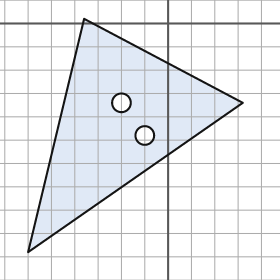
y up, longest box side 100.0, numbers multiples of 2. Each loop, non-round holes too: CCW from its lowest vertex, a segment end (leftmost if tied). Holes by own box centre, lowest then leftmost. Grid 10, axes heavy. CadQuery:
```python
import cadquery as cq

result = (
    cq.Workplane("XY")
    .moveTo(-60.0, -98.0)
    .lineTo(32.0, -34.0)
    .lineTo(-36.0, 2.0)
    .close()
    .moveTo(-10.0, -48.0)
    .circle(4.0)
    .moveTo(-20.0, -34.0)
    .circle(4.0)
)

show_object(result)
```